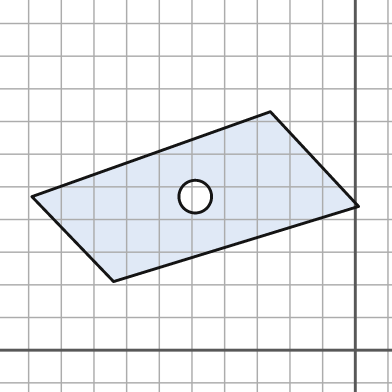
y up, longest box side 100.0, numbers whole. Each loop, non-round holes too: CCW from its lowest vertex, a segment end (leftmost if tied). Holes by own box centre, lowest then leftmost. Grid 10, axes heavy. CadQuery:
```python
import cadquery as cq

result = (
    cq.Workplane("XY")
    .moveTo(-74.0, 21.0)
    .lineTo(1.0, 44.0)
    .lineTo(-26.0, 73.0)
    .lineTo(-99.0, 47.0)
    .close()
    .moveTo(-49.0, 47.0)
    .circle(5.0)
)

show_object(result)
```